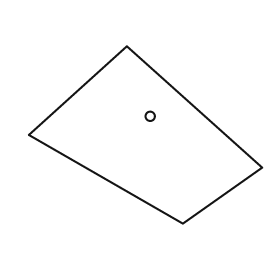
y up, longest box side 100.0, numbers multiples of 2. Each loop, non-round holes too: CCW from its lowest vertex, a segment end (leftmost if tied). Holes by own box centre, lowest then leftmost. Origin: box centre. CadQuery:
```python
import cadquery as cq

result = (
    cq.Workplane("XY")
    .moveTo(16.0, -38.0)
    .lineTo(50.0, -14.0)
    .lineTo(-8.0, 38.0)
    .lineTo(-50.0, 0.0)
    .close()
    .moveTo(2.0, 8.0)
    .circle(2.0)
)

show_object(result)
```